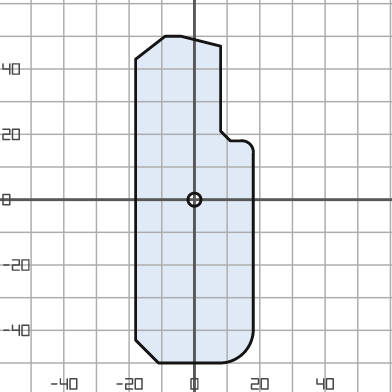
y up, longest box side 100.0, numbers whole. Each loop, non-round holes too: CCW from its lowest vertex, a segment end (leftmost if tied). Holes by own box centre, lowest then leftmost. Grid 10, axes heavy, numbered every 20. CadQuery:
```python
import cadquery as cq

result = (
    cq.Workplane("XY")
    .moveTo(-11.0, -50.0)
    .lineTo(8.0, -50.0)
    .threePointArc((15.0, -47.0), (18.0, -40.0))
    .lineTo(18.0, 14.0)
    .threePointArc((17.0, 17.0), (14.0, 18.0))
    .lineTo(11.0, 18.0)
    .lineTo(8.0, 21.0)
    .lineTo(8.0, 47.0)
    .lineTo(-4.0, 50.0)
    .lineTo(-9.0, 50.0)
    .lineTo(-18.0, 43.0)
    .lineTo(-18.0, -43.0)
    .close()
    .moveTo(0.0, 0.0)
    .circle(2.0)
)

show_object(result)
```